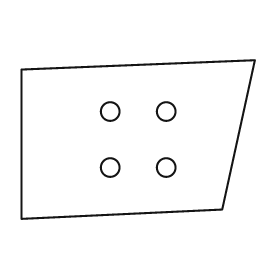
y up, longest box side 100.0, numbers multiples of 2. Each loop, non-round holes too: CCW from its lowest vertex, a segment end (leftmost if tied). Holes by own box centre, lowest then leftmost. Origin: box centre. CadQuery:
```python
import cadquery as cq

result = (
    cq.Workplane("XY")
    .moveTo(-50.0, -34.0)
    .lineTo(36.0, -30.0)
    .lineTo(50.0, 34.0)
    .lineTo(-50.0, 30.0)
    .close()
    .moveTo(-12.0, -12.0)
    .circle(4.0)
    .moveTo(12.0, -12.0)
    .circle(4.0)
    .moveTo(-12.0, 12.0)
    .circle(4.0)
    .moveTo(12.0, 12.0)
    .circle(4.0)
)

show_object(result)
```